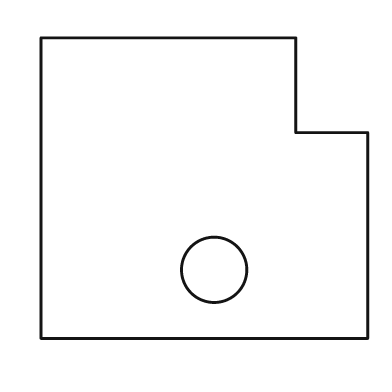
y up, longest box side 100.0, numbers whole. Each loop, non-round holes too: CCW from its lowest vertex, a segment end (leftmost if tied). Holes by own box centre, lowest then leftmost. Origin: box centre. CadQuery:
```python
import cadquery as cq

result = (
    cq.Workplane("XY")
    .moveTo(-50.0, -46.0)
    .lineTo(50.0, -46.0)
    .lineTo(50.0, 17.0)
    .lineTo(28.0, 17.0)
    .lineTo(28.0, 46.0)
    .lineTo(-50.0, 46.0)
    .close()
    .moveTo(3.0, -25.0)
    .circle(10.0)
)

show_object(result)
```